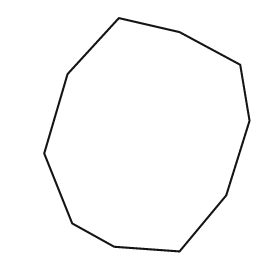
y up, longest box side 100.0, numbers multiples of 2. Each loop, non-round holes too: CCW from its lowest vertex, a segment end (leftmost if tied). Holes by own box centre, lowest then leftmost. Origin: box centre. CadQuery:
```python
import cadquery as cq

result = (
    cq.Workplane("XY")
    .moveTo(14.0, -50.0)
    .lineTo(34.0, -26.0)
    .lineTo(44.0, 6.0)
    .lineTo(40.0, 30.0)
    .lineTo(14.0, 44.0)
    .lineTo(-12.0, 50.0)
    .lineTo(-34.0, 26.0)
    .lineTo(-44.0, -8.0)
    .lineTo(-32.0, -38.0)
    .lineTo(-14.0, -48.0)
    .close()
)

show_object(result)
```